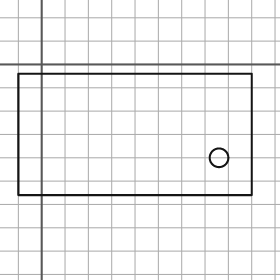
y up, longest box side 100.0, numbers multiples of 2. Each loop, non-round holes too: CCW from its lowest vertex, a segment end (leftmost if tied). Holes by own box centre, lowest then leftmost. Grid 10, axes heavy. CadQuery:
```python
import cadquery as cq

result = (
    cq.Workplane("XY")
    .moveTo(-10.0, -56.0)
    .lineTo(90.0, -56.0)
    .lineTo(90.0, -4.0)
    .lineTo(-10.0, -4.0)
    .close()
    .moveTo(76.0, -40.0)
    .circle(4.0)
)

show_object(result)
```